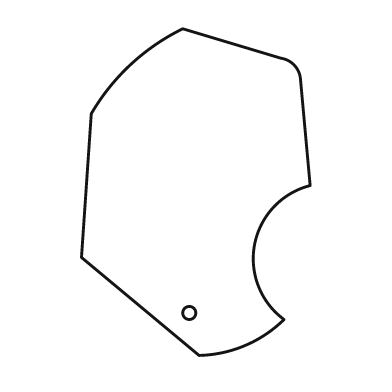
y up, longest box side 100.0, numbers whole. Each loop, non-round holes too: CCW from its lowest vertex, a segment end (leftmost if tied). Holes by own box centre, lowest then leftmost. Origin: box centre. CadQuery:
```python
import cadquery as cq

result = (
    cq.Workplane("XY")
    .moveTo(1.0, -50.0)
    .threePointArc((15.0, -47.0), (27.0, -39.0))
    .threePointArc((18.0, -16.0), (35.0, 2.0))
    .lineTo(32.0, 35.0)
    .threePointArc((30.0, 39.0), (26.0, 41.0))
    .lineTo(-4.0, 50.0)
    .threePointArc((-20.0, 39.0), (-32.0, 24.0))
    .lineTo(-35.0, -20.0)
    .close()
    .moveTo(-2.0, -37.0)
    .circle(2.0)
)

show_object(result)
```